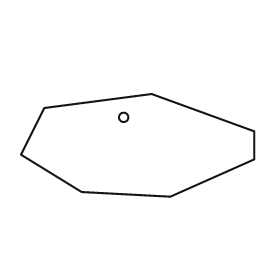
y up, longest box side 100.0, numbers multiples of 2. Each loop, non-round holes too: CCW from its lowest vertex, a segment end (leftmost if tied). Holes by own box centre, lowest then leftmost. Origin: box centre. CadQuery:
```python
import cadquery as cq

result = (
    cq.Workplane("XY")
    .moveTo(14.0, -22.0)
    .lineTo(50.0, -6.0)
    .lineTo(50.0, 6.0)
    .lineTo(6.0, 22.0)
    .lineTo(-40.0, 16.0)
    .lineTo(-50.0, -4.0)
    .lineTo(-24.0, -20.0)
    .close()
    .moveTo(-6.0, 12.0)
    .circle(2.0)
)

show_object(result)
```